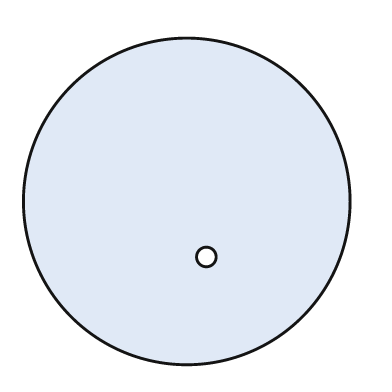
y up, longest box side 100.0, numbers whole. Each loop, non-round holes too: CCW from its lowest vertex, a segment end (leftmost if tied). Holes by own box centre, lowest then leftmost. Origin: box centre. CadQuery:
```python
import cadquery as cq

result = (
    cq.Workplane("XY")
    .moveTo(0.0, 0.0)
    .circle(50.0)
    .moveTo(6.0, -17.0)
    .circle(3.0)
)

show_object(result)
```